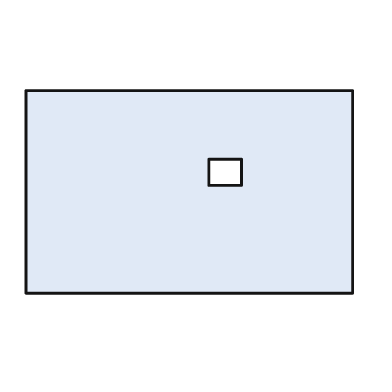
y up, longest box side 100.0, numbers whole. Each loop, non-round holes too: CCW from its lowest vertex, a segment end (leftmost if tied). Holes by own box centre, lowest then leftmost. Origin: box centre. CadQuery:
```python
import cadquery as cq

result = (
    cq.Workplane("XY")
    .moveTo(-50.0, -31.0)
    .lineTo(50.0, -31.0)
    .lineTo(50.0, 31.0)
    .lineTo(-50.0, 31.0)
    .close()
    .moveTo(6.0, 2.0)
    .lineTo(16.0, 2.0)
    .lineTo(16.0, 10.0)
    .lineTo(6.0, 10.0)
    .close()
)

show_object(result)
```